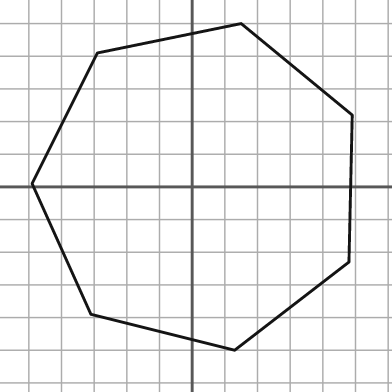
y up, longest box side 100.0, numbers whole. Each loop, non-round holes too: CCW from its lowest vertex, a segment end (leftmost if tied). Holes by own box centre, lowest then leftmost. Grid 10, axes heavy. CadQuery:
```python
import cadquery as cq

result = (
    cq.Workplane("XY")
    .moveTo(13.0, -50.0)
    .lineTo(48.0, -23.0)
    .lineTo(49.0, 22.0)
    .lineTo(15.0, 50.0)
    .lineTo(-29.0, 41.0)
    .lineTo(-49.0, 1.0)
    .lineTo(-31.0, -39.0)
    .close()
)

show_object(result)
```